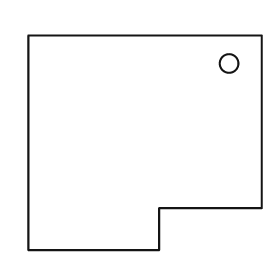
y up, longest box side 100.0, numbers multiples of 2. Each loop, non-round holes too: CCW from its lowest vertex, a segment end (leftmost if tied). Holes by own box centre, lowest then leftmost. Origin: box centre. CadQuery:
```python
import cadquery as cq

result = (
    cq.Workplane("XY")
    .moveTo(-50.0, -46.0)
    .lineTo(6.0, -46.0)
    .lineTo(6.0, -28.0)
    .lineTo(50.0, -28.0)
    .lineTo(50.0, 46.0)
    .lineTo(-50.0, 46.0)
    .close()
    .moveTo(36.0, 34.0)
    .circle(4.0)
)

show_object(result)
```